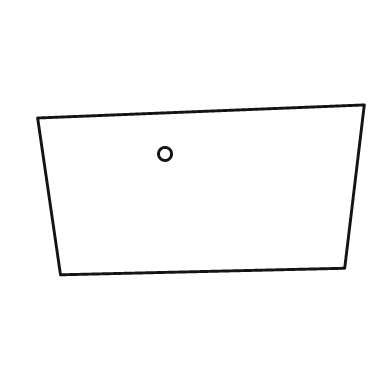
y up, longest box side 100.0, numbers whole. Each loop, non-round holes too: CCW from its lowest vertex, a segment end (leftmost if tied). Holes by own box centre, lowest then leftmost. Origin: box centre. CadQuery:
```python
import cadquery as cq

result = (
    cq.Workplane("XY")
    .moveTo(-43.0, -26.0)
    .lineTo(44.0, -24.0)
    .lineTo(50.0, 26.0)
    .lineTo(-50.0, 22.0)
    .close()
    .moveTo(-11.0, 11.0)
    .circle(2.0)
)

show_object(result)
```